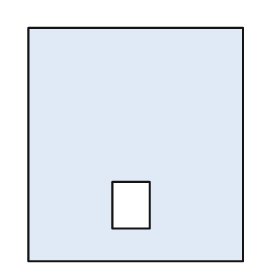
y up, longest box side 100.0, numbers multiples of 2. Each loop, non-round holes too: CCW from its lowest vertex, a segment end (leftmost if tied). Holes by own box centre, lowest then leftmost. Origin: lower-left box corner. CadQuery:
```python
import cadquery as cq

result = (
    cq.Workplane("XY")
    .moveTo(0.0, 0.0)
    .lineTo(92.0, 0.0)
    .lineTo(92.0, 100.0)
    .lineTo(0.0, 100.0)
    .close()
    .moveTo(36.0, 14.0)
    .lineTo(52.0, 14.0)
    .lineTo(52.0, 34.0)
    .lineTo(36.0, 34.0)
    .close()
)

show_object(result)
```